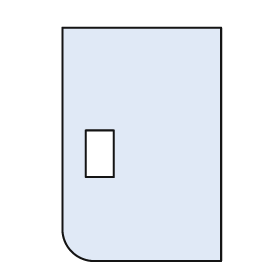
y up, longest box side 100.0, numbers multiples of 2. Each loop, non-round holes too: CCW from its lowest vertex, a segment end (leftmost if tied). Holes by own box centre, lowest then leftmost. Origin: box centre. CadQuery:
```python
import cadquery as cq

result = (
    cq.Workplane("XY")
    .moveTo(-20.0, -50.0)
    .lineTo(34.0, -50.0)
    .lineTo(34.0, 50.0)
    .lineTo(-34.0, 50.0)
    .lineTo(-34.0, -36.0)
    .threePointArc((-30.0, -46.0), (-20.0, -50.0))
    .close()
    .moveTo(-24.0, -14.0)
    .lineTo(-12.0, -14.0)
    .lineTo(-12.0, 6.0)
    .lineTo(-24.0, 6.0)
    .close()
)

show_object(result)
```